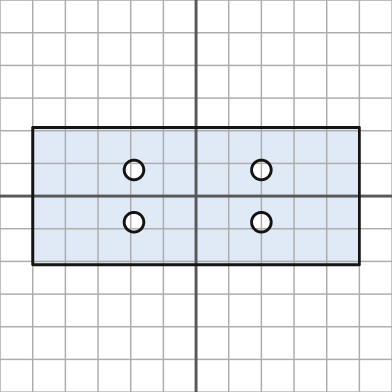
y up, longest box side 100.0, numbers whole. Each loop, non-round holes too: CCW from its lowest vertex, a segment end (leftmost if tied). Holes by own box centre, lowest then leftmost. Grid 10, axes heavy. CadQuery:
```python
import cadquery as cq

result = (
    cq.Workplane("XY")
    .moveTo(-50.0, -21.0)
    .lineTo(50.0, -21.0)
    .lineTo(50.0, 21.0)
    .lineTo(-50.0, 21.0)
    .close()
    .moveTo(-19.0, -8.0)
    .circle(3.0)
    .moveTo(20.0, -8.0)
    .circle(3.0)
    .moveTo(-19.0, 8.0)
    .circle(3.0)
    .moveTo(20.0, 8.0)
    .circle(3.0)
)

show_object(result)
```